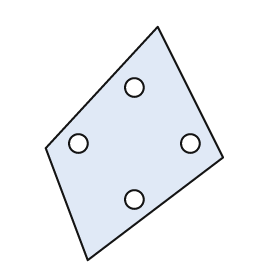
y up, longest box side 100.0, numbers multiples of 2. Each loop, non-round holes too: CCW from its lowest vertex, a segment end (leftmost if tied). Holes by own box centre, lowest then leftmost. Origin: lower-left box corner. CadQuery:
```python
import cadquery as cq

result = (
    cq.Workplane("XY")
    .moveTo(18.0, 0.0)
    .lineTo(76.0, 44.0)
    .lineTo(48.0, 100.0)
    .lineTo(0.0, 48.0)
    .close()
    .moveTo(38.0, 26.0)
    .circle(4.0)
    .moveTo(14.0, 50.0)
    .circle(4.0)
    .moveTo(62.0, 50.0)
    .circle(4.0)
    .moveTo(38.0, 74.0)
    .circle(4.0)
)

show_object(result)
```